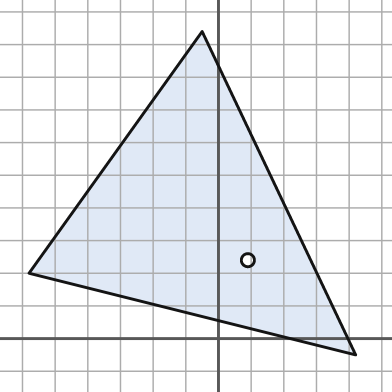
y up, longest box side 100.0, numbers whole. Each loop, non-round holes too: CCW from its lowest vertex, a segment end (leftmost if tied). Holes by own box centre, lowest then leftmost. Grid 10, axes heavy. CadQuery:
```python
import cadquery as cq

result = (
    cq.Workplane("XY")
    .moveTo(42.0, -5.0)
    .lineTo(-5.0, 94.0)
    .lineTo(-58.0, 20.0)
    .close()
    .moveTo(9.0, 24.0)
    .circle(2.0)
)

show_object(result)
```